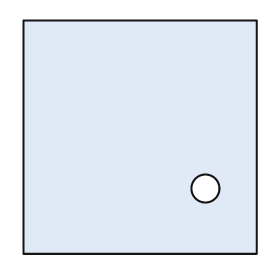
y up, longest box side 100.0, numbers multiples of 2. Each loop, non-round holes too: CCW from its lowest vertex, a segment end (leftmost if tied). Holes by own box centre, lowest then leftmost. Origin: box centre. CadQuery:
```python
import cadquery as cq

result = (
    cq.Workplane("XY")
    .moveTo(-50.0, -50.0)
    .lineTo(50.0, -50.0)
    .lineTo(50.0, 50.0)
    .lineTo(-50.0, 50.0)
    .close()
    .moveTo(28.0, -22.0)
    .circle(6.0)
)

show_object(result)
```